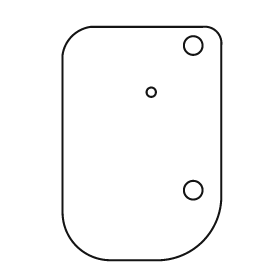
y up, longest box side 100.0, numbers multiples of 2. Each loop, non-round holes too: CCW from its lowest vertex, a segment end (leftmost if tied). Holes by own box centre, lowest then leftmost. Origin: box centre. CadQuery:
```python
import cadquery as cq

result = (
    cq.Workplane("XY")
    .moveTo(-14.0, -50.0)
    .lineTo(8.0, -50.0)
    .threePointArc((26.0, -42.0), (34.0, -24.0))
    .lineTo(34.0, 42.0)
    .threePointArc((32.0, 48.0), (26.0, 50.0))
    .lineTo(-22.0, 50.0)
    .threePointArc((-30.0, 46.0), (-34.0, 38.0))
    .lineTo(-34.0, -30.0)
    .threePointArc((-28.0, -44.0), (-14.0, -50.0))
    .close()
    .moveTo(22.0, -20.0)
    .circle(4.0)
    .moveTo(4.0, 22.0)
    .circle(2.0)
    .moveTo(22.0, 42.0)
    .circle(4.0)
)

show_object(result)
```